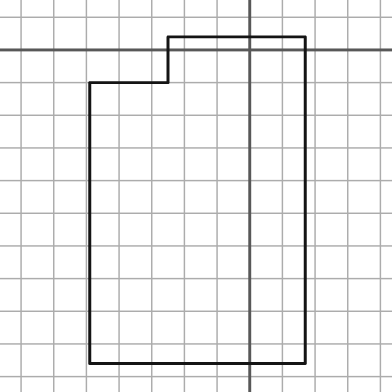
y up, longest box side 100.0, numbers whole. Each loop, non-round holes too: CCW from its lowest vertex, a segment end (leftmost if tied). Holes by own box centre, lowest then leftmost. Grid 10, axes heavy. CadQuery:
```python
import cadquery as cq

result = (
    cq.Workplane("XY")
    .moveTo(-49.0, -96.0)
    .lineTo(17.0, -96.0)
    .lineTo(17.0, 4.0)
    .lineTo(-25.0, 4.0)
    .lineTo(-25.0, -10.0)
    .lineTo(-49.0, -10.0)
    .close()
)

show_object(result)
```